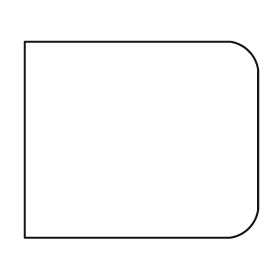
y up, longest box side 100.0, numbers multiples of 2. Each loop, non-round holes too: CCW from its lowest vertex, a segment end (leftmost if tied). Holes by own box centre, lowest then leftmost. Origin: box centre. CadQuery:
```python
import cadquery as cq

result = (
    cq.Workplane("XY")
    .moveTo(-50.0, -42.0)
    .lineTo(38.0, -42.0)
    .threePointArc((46.0, -38.0), (50.0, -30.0))
    .lineTo(50.0, 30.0)
    .threePointArc((46.0, 38.0), (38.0, 42.0))
    .lineTo(-50.0, 42.0)
    .close()
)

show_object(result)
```